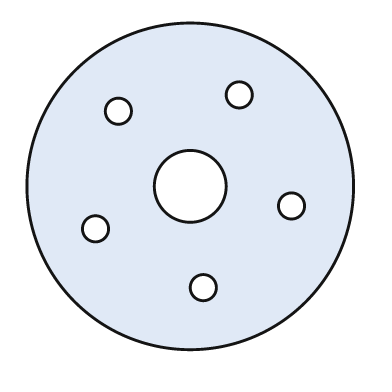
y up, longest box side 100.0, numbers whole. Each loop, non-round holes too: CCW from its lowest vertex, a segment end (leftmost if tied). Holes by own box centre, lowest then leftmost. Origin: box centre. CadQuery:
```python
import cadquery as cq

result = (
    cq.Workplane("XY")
    .moveTo(0.0, 0.0)
    .circle(50.0)
    .moveTo(4.0, -31.0)
    .circle(4.0)
    .moveTo(-29.0, -13.0)
    .circle(4.0)
    .moveTo(31.0, -6.0)
    .circle(4.0)
    .moveTo(0.0, 0.0)
    .circle(11.0)
    .moveTo(-22.0, 23.0)
    .circle(4.0)
    .moveTo(15.0, 28.0)
    .circle(4.0)
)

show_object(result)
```